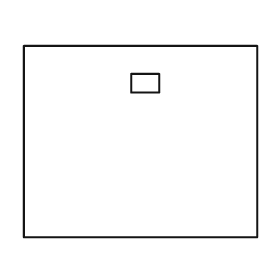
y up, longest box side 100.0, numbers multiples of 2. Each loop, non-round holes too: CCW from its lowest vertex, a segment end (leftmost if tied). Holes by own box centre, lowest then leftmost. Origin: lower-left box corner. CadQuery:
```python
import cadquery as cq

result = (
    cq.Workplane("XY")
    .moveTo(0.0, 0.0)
    .lineTo(100.0, 0.0)
    .lineTo(100.0, 82.0)
    .lineTo(0.0, 82.0)
    .close()
    .moveTo(46.0, 62.0)
    .lineTo(58.0, 62.0)
    .lineTo(58.0, 70.0)
    .lineTo(46.0, 70.0)
    .close()
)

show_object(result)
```